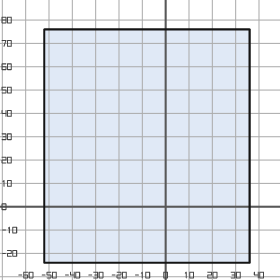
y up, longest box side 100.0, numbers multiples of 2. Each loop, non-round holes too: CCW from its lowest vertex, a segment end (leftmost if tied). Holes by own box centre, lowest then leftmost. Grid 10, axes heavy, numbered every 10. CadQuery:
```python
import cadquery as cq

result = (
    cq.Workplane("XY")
    .moveTo(-52.0, -24.0)
    .lineTo(36.0, -24.0)
    .lineTo(36.0, 76.0)
    .lineTo(-52.0, 76.0)
    .close()
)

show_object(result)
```